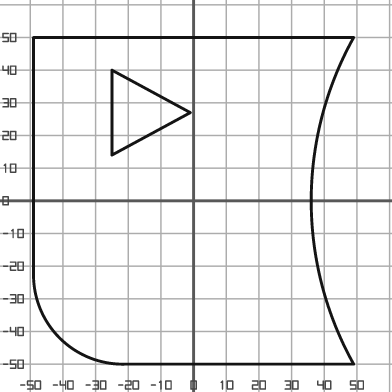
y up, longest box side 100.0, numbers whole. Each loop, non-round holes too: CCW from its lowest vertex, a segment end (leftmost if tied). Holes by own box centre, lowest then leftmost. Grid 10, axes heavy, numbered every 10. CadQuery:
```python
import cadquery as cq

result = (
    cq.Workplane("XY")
    .moveTo(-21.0, -50.0)
    .lineTo(49.0, -50.0)
    .threePointArc((36.0, 0.0), (49.0, 50.0))
    .lineTo(-49.0, 50.0)
    .lineTo(-49.0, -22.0)
    .threePointArc((-41.0, -42.0), (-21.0, -50.0))
    .close()
    .moveTo(-25.0, 14.0)
    .lineTo(-1.0, 27.0)
    .lineTo(-25.0, 40.0)
    .close()
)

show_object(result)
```